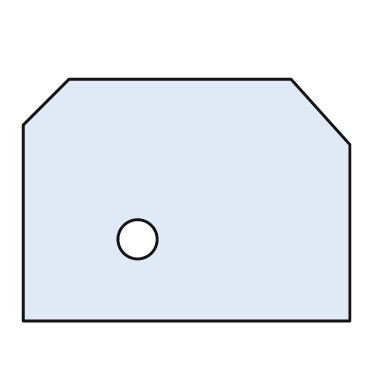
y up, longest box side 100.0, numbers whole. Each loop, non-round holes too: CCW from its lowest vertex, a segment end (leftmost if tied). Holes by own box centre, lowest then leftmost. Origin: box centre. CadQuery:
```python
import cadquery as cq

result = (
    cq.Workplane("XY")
    .moveTo(-50.0, -37.0)
    .lineTo(50.0, -37.0)
    .lineTo(50.0, 17.0)
    .lineTo(32.0, 37.0)
    .lineTo(-36.0, 37.0)
    .lineTo(-50.0, 23.0)
    .close()
    .moveTo(-15.0, -12.0)
    .circle(6.0)
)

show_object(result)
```